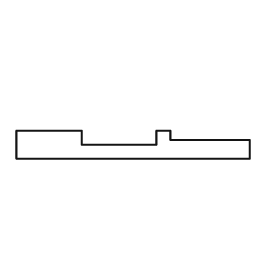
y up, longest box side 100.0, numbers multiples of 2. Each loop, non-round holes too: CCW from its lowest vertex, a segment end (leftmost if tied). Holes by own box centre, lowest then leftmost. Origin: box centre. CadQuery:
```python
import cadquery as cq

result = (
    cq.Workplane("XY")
    .moveTo(-50.0, -6.0)
    .lineTo(50.0, -6.0)
    .lineTo(50.0, 2.0)
    .lineTo(16.0, 2.0)
    .lineTo(16.0, 6.0)
    .lineTo(10.0, 6.0)
    .lineTo(10.0, 0.0)
    .lineTo(-22.0, 0.0)
    .lineTo(-22.0, 6.0)
    .lineTo(-50.0, 6.0)
    .close()
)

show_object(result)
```